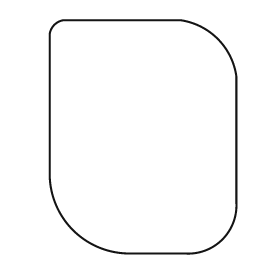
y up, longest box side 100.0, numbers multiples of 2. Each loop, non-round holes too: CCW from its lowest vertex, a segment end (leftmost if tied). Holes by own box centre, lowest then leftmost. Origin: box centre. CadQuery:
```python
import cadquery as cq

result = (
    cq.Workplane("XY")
    .moveTo(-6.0, -50.0)
    .lineTo(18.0, -50.0)
    .threePointArc((34.0, -44.0), (40.0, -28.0))
    .lineTo(40.0, 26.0)
    .threePointArc((32.0, 42.0), (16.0, 50.0))
    .lineTo(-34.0, 50.0)
    .threePointArc((-38.0, 48.0), (-40.0, 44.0))
    .lineTo(-40.0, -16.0)
    .threePointArc((-30.0, -40.0), (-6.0, -50.0))
    .close()
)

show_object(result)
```